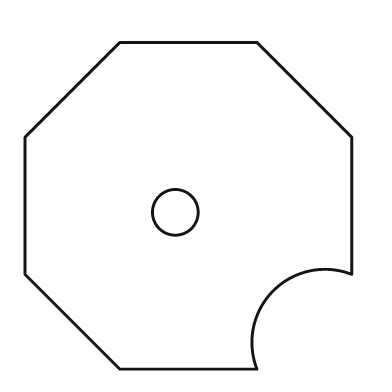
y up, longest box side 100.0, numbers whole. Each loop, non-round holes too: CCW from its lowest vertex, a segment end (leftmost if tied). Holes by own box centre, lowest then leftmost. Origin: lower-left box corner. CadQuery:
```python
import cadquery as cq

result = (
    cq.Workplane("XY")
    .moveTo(29.0, 0.0)
    .lineTo(71.0, 0.0)
    .threePointArc((76.0, 24.0), (100.0, 29.0))
    .lineTo(100.0, 71.0)
    .lineTo(71.0, 100.0)
    .lineTo(29.0, 100.0)
    .lineTo(0.0, 71.0)
    .lineTo(0.0, 29.0)
    .close()
    .moveTo(46.0, 48.0)
    .circle(7.0)
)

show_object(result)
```